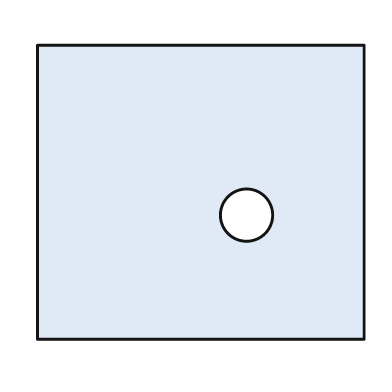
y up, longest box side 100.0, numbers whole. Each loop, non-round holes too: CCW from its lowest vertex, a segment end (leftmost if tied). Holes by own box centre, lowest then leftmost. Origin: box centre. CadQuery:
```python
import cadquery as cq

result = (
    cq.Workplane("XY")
    .moveTo(-50.0, -45.0)
    .lineTo(50.0, -45.0)
    .lineTo(50.0, 45.0)
    .lineTo(-50.0, 45.0)
    .close()
    .moveTo(14.0, -7.0)
    .circle(8.0)
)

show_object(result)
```